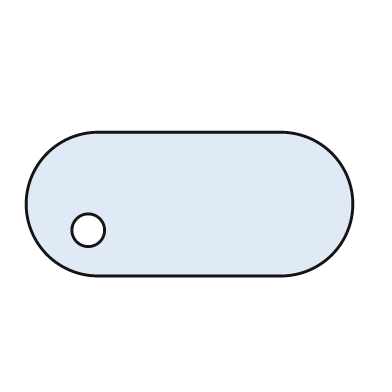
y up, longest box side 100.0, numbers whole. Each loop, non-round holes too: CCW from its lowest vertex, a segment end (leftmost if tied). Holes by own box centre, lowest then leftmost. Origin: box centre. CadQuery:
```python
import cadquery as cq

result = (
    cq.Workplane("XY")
    .moveTo(-28.0, -22.0)
    .lineTo(28.0, -22.0)
    .threePointArc((50.0, 0.0), (28.0, 22.0))
    .lineTo(-28.0, 22.0)
    .threePointArc((-50.0, 0.0), (-28.0, -22.0))
    .close()
    .moveTo(-31.0, -8.0)
    .circle(5.0)
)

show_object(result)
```